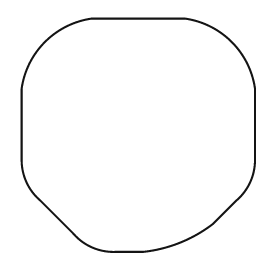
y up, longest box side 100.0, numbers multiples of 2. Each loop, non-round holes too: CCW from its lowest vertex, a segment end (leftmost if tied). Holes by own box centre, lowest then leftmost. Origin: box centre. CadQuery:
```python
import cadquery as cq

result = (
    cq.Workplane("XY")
    .moveTo(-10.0, -50.0)
    .lineTo(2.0, -50.0)
    .threePointArc((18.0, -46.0), (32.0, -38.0))
    .lineTo(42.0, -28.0)
    .threePointArc((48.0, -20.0), (50.0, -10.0))
    .lineTo(50.0, 20.0)
    .threePointArc((40.0, 40.0), (20.0, 50.0))
    .lineTo(-20.0, 50.0)
    .threePointArc((-40.0, 40.0), (-50.0, 20.0))
    .lineTo(-50.0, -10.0)
    .threePointArc((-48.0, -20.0), (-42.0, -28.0))
    .lineTo(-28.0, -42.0)
    .threePointArc((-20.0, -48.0), (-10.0, -50.0))
    .close()
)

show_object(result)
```